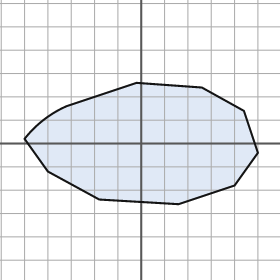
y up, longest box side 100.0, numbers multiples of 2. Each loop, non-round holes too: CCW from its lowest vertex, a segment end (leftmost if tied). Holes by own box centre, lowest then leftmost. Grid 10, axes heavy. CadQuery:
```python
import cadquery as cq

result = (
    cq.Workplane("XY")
    .moveTo(16.0, -26.0)
    .lineTo(40.0, -18.0)
    .lineTo(50.0, -4.0)
    .lineTo(44.0, 14.0)
    .lineTo(26.0, 24.0)
    .lineTo(-2.0, 26.0)
    .lineTo(-32.0, 16.0)
    .threePointArc((-42.0, 10.0), (-50.0, 2.0))
    .lineTo(-40.0, -12.0)
    .lineTo(-18.0, -24.0)
    .close()
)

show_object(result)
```